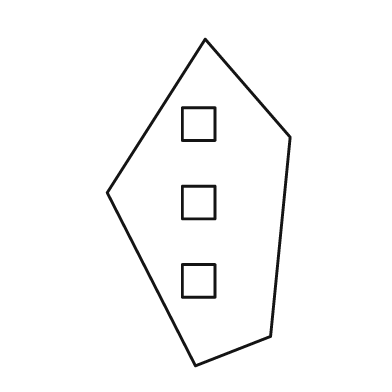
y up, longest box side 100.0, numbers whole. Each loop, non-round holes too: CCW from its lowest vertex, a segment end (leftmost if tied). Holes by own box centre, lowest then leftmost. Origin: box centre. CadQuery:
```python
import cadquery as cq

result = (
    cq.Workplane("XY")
    .moveTo(-1.0, -50.0)
    .lineTo(22.0, -41.0)
    .lineTo(28.0, 20.0)
    .lineTo(2.0, 50.0)
    .lineTo(-28.0, 3.0)
    .close()
    .moveTo(-5.0, -29.0)
    .lineTo(5.0, -29.0)
    .lineTo(5.0, -19.0)
    .lineTo(-5.0, -19.0)
    .close()
    .moveTo(-5.0, -5.0)
    .lineTo(5.0, -5.0)
    .lineTo(5.0, 5.0)
    .lineTo(-5.0, 5.0)
    .close()
    .moveTo(-5.0, 19.0)
    .lineTo(5.0, 19.0)
    .lineTo(5.0, 29.0)
    .lineTo(-5.0, 29.0)
    .close()
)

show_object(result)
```